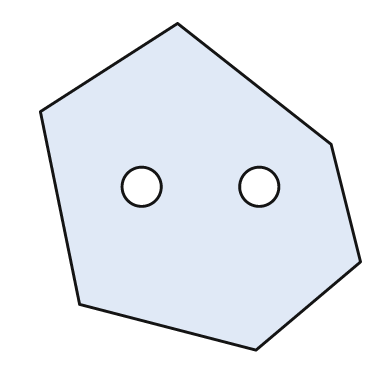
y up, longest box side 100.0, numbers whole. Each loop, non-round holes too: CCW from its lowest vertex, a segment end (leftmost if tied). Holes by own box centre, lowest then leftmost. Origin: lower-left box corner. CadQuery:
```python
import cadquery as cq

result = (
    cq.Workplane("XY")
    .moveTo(66.0, 0.0)
    .lineTo(98.0, 27.0)
    .lineTo(89.0, 63.0)
    .lineTo(42.0, 100.0)
    .lineTo(0.0, 73.0)
    .lineTo(12.0, 14.0)
    .close()
    .moveTo(31.0, 50.0)
    .circle(6.0)
    .moveTo(67.0, 50.0)
    .circle(6.0)
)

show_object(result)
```